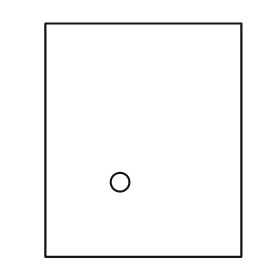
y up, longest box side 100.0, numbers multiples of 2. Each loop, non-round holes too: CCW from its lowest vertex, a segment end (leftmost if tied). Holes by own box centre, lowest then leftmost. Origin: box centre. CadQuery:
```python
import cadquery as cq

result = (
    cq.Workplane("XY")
    .moveTo(-42.0, -50.0)
    .lineTo(42.0, -50.0)
    .lineTo(42.0, 50.0)
    .lineTo(-42.0, 50.0)
    .close()
    .moveTo(-10.0, -18.0)
    .circle(4.0)
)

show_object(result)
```